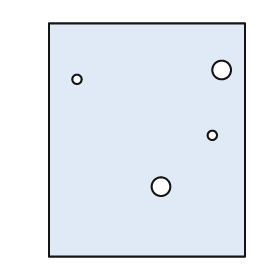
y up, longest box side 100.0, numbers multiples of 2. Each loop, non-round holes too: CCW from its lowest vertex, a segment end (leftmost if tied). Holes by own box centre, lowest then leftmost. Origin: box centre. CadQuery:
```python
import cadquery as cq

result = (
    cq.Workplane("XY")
    .moveTo(-42.0, -50.0)
    .lineTo(42.0, -50.0)
    .lineTo(42.0, 50.0)
    .lineTo(-42.0, 50.0)
    .close()
    .moveTo(6.0, -20.0)
    .circle(4.0)
    .moveTo(28.0, 2.0)
    .circle(2.0)
    .moveTo(-30.0, 26.0)
    .circle(2.0)
    .moveTo(32.0, 30.0)
    .circle(4.0)
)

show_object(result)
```